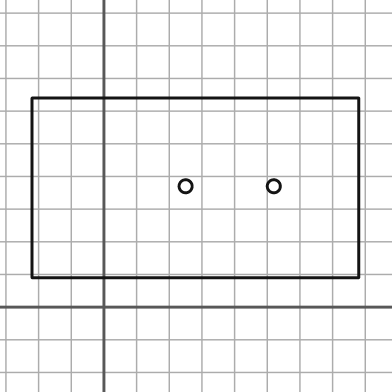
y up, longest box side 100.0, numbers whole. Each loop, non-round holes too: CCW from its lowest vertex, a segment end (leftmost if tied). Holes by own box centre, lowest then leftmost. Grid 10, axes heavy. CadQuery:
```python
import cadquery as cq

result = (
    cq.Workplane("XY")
    .moveTo(-22.0, 9.0)
    .lineTo(78.0, 9.0)
    .lineTo(78.0, 64.0)
    .lineTo(-22.0, 64.0)
    .close()
    .moveTo(25.0, 37.0)
    .circle(2.0)
    .moveTo(52.0, 37.0)
    .circle(2.0)
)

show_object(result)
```